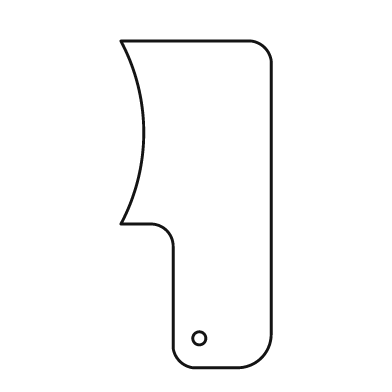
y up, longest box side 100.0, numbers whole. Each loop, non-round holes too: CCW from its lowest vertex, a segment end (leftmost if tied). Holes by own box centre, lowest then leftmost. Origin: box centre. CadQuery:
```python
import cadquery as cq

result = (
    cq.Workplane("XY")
    .moveTo(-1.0, -50.0)
    .lineTo(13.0, -50.0)
    .threePointArc((20.0, -47.0), (23.0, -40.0))
    .lineTo(23.0, 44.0)
    .threePointArc((21.0, 48.0), (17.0, 50.0))
    .lineTo(-23.0, 50.0)
    .threePointArc((-16.0, 22.0), (-23.0, -6.0))
    .lineTo(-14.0, -6.0)
    .threePointArc((-9.0, -8.0), (-7.0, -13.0))
    .lineTo(-7.0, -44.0)
    .threePointArc((-5.0, -48.0), (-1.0, -50.0))
    .close()
    .moveTo(1.0, -41.0)
    .circle(2.0)
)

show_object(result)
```